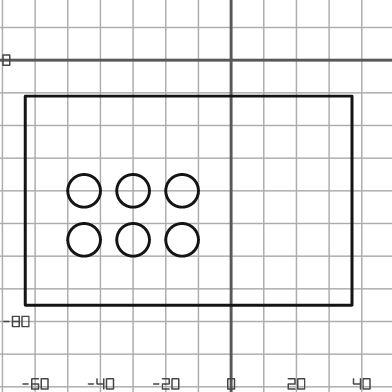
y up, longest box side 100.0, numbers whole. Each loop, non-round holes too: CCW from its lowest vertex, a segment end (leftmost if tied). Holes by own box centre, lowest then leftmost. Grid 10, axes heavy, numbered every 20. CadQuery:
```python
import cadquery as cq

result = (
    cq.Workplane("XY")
    .moveTo(-63.0, -75.0)
    .lineTo(37.0, -75.0)
    .lineTo(37.0, -11.0)
    .lineTo(-63.0, -11.0)
    .close()
    .moveTo(-45.0, -55.0)
    .circle(5.0)
    .moveTo(-30.0, -55.0)
    .circle(5.0)
    .moveTo(-15.0, -55.0)
    .circle(5.0)
    .moveTo(-45.0, -40.0)
    .circle(5.0)
    .moveTo(-30.0, -40.0)
    .circle(5.0)
    .moveTo(-15.0, -40.0)
    .circle(5.0)
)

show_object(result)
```